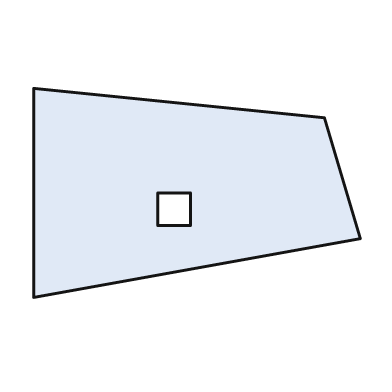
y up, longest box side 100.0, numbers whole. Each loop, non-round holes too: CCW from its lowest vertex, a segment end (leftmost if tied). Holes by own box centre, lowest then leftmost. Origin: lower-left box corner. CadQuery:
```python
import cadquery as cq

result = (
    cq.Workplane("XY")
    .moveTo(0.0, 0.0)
    .lineTo(100.0, 18.0)
    .lineTo(89.0, 55.0)
    .lineTo(0.0, 64.0)
    .close()
    .moveTo(38.0, 22.0)
    .lineTo(48.0, 22.0)
    .lineTo(48.0, 32.0)
    .lineTo(38.0, 32.0)
    .close()
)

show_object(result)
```